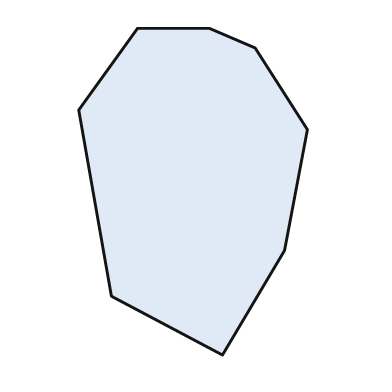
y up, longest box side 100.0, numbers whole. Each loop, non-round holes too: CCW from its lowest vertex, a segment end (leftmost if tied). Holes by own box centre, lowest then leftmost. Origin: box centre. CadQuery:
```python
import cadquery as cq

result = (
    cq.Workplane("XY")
    .moveTo(9.0, -50.0)
    .lineTo(28.0, -18.0)
    .lineTo(35.0, 19.0)
    .lineTo(19.0, 44.0)
    .lineTo(5.0, 50.0)
    .lineTo(-17.0, 50.0)
    .lineTo(-35.0, 25.0)
    .lineTo(-25.0, -32.0)
    .close()
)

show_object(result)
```